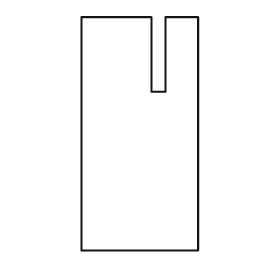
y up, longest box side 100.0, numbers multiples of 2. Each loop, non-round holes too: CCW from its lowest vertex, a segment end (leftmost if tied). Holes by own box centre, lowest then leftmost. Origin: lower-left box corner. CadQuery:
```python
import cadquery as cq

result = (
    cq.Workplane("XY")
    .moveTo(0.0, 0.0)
    .lineTo(50.0, 0.0)
    .lineTo(50.0, 100.0)
    .lineTo(36.0, 100.0)
    .lineTo(36.0, 68.0)
    .lineTo(30.0, 68.0)
    .lineTo(30.0, 100.0)
    .lineTo(0.0, 100.0)
    .close()
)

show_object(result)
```